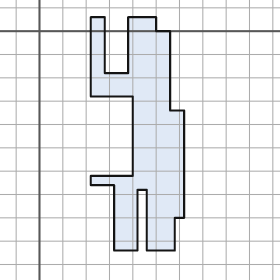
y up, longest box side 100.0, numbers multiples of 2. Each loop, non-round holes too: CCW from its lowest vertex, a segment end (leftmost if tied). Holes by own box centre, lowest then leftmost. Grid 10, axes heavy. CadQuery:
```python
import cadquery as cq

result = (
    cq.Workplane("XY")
    .moveTo(32.0, -94.0)
    .lineTo(42.0, -94.0)
    .lineTo(42.0, -68.0)
    .lineTo(46.0, -68.0)
    .lineTo(46.0, -94.0)
    .lineTo(58.0, -94.0)
    .lineTo(58.0, -80.0)
    .lineTo(62.0, -80.0)
    .lineTo(62.0, -34.0)
    .lineTo(56.0, -34.0)
    .lineTo(56.0, 0.0)
    .lineTo(50.0, 0.0)
    .lineTo(50.0, 6.0)
    .lineTo(38.0, 6.0)
    .lineTo(38.0, -18.0)
    .lineTo(28.0, -18.0)
    .lineTo(28.0, 6.0)
    .lineTo(22.0, 6.0)
    .lineTo(22.0, -28.0)
    .lineTo(40.0, -28.0)
    .lineTo(40.0, -62.0)
    .lineTo(22.0, -62.0)
    .lineTo(22.0, -66.0)
    .lineTo(32.0, -66.0)
    .close()
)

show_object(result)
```